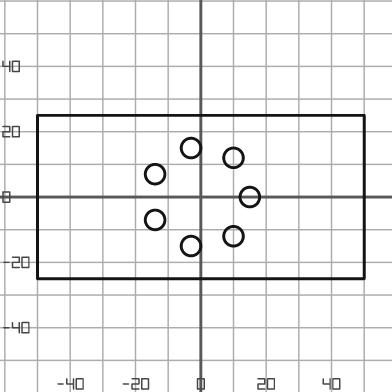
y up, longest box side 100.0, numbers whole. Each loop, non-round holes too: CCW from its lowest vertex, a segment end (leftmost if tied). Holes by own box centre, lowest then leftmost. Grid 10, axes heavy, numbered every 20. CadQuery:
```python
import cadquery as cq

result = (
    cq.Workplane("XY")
    .moveTo(-50.0, -25.0)
    .lineTo(50.0, -25.0)
    .lineTo(50.0, 25.0)
    .lineTo(-50.0, 25.0)
    .close()
    .moveTo(-3.0, -15.0)
    .circle(3.0)
    .moveTo(10.0, -12.0)
    .circle(3.0)
    .moveTo(-14.0, -7.0)
    .circle(3.0)
    .moveTo(15.0, 0.0)
    .circle(3.0)
    .moveTo(-14.0, 7.0)
    .circle(3.0)
    .moveTo(10.0, 12.0)
    .circle(3.0)
    .moveTo(-3.0, 15.0)
    .circle(3.0)
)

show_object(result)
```